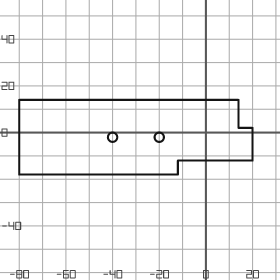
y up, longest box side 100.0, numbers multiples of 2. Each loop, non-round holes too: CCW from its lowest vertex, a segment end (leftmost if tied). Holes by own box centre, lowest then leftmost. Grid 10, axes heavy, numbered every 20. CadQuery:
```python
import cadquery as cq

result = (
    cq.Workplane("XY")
    .moveTo(-80.0, -18.0)
    .lineTo(-12.0, -18.0)
    .lineTo(-12.0, -12.0)
    .lineTo(20.0, -12.0)
    .lineTo(20.0, 2.0)
    .lineTo(14.0, 2.0)
    .lineTo(14.0, 14.0)
    .lineTo(-80.0, 14.0)
    .close()
    .moveTo(-40.0, -2.0)
    .circle(2.0)
    .moveTo(-20.0, -2.0)
    .circle(2.0)
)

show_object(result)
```